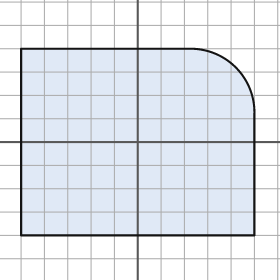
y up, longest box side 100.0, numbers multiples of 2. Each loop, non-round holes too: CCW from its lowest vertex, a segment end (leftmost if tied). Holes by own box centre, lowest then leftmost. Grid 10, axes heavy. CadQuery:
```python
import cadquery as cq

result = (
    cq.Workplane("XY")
    .moveTo(-50.0, -40.0)
    .lineTo(50.0, -40.0)
    .lineTo(50.0, 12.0)
    .threePointArc((42.0, 32.0), (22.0, 40.0))
    .lineTo(-50.0, 40.0)
    .close()
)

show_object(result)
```